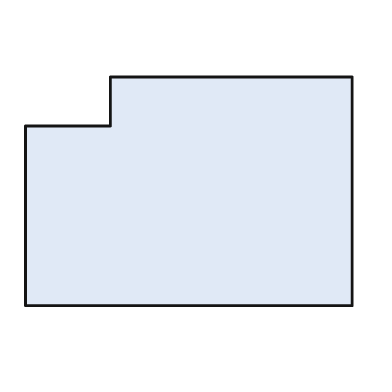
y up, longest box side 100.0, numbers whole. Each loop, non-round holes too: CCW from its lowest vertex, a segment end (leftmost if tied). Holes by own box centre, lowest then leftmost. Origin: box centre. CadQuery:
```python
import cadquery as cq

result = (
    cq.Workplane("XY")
    .moveTo(-50.0, -35.0)
    .lineTo(50.0, -35.0)
    .lineTo(50.0, 35.0)
    .lineTo(-24.0, 35.0)
    .lineTo(-24.0, 20.0)
    .lineTo(-50.0, 20.0)
    .close()
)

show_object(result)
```